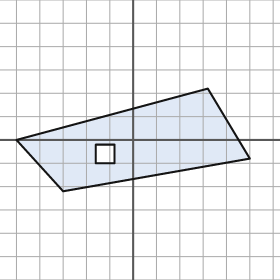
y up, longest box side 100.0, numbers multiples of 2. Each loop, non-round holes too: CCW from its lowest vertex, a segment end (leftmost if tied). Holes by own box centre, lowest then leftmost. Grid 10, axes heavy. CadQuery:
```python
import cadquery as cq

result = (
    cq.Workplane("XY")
    .moveTo(-30.0, -22.0)
    .lineTo(50.0, -8.0)
    .lineTo(32.0, 22.0)
    .lineTo(-50.0, 0.0)
    .close()
    .moveTo(-16.0, -10.0)
    .lineTo(-8.0, -10.0)
    .lineTo(-8.0, -2.0)
    .lineTo(-16.0, -2.0)
    .close()
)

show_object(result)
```